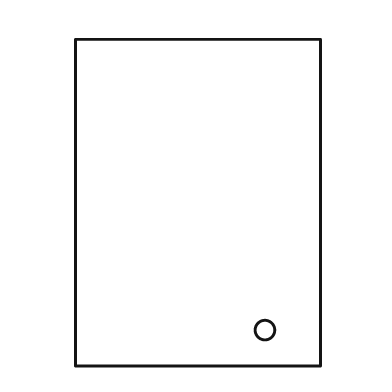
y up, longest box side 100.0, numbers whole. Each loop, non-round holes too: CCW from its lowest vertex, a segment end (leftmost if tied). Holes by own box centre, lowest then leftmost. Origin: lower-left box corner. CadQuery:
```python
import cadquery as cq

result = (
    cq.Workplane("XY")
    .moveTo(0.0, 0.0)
    .lineTo(75.0, 0.0)
    .lineTo(75.0, 100.0)
    .lineTo(0.0, 100.0)
    .close()
    .moveTo(58.0, 11.0)
    .circle(3.0)
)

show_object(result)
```